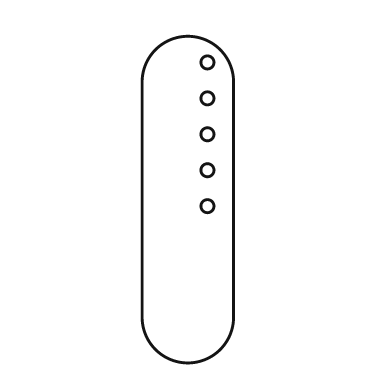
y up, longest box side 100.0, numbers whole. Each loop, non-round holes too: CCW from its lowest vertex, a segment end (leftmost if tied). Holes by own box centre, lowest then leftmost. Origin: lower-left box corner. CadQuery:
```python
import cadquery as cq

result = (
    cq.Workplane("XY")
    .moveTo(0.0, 14.0)
    .threePointArc((14.0, 0.0), (28.0, 14.0))
    .lineTo(28.0, 86.0)
    .threePointArc((14.0, 100.0), (0.0, 86.0))
    .close()
    .moveTo(20.0, 48.0)
    .circle(2.0)
    .moveTo(20.0, 59.0)
    .circle(2.0)
    .moveTo(20.0, 70.0)
    .circle(2.0)
    .moveTo(20.0, 81.0)
    .circle(2.0)
    .moveTo(20.0, 92.0)
    .circle(2.0)
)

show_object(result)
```